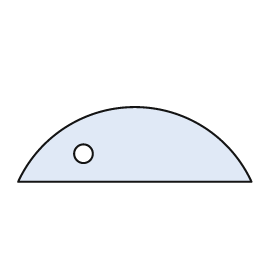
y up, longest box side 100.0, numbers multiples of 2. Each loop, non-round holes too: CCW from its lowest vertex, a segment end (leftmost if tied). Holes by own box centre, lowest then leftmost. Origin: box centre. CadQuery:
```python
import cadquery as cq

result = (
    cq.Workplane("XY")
    .moveTo(-50.0, -16.0)
    .lineTo(50.0, -16.0)
    .threePointArc((0.0, 16.0), (-50.0, -16.0))
    .close()
    .moveTo(-22.0, -4.0)
    .circle(4.0)
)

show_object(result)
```